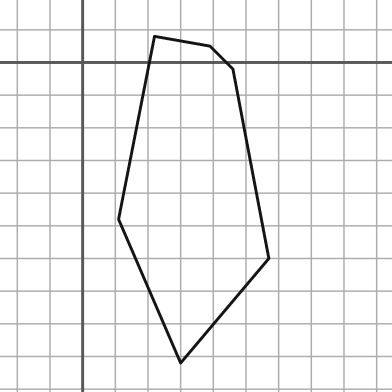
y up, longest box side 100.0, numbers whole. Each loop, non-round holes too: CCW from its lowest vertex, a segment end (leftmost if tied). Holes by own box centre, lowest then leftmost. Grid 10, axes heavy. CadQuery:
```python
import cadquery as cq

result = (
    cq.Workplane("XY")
    .moveTo(30.0, -92.0)
    .lineTo(57.0, -60.0)
    .lineTo(46.0, -2.0)
    .lineTo(39.0, 5.0)
    .lineTo(22.0, 8.0)
    .lineTo(11.0, -48.0)
    .close()
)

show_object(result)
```